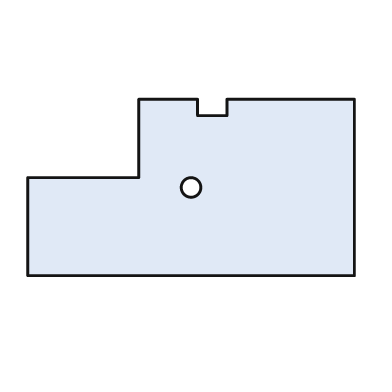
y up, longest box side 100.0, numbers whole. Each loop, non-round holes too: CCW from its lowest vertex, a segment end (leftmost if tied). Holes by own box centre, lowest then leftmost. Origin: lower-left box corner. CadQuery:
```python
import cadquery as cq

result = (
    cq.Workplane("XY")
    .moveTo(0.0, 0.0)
    .lineTo(100.0, 0.0)
    .lineTo(100.0, 54.0)
    .lineTo(61.0, 54.0)
    .lineTo(61.0, 49.0)
    .lineTo(52.0, 49.0)
    .lineTo(52.0, 54.0)
    .lineTo(34.0, 54.0)
    .lineTo(34.0, 30.0)
    .lineTo(0.0, 30.0)
    .close()
    .moveTo(50.0, 27.0)
    .circle(3.0)
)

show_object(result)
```